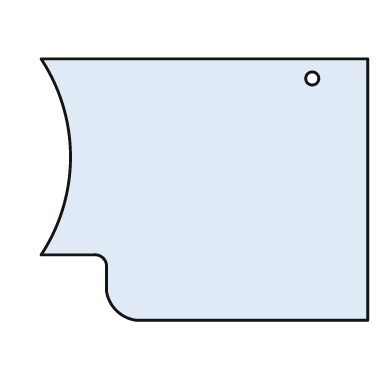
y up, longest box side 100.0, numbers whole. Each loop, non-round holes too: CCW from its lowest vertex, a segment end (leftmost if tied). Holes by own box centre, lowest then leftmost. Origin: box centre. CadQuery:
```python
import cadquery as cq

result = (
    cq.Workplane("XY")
    .moveTo(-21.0, -40.0)
    .lineTo(50.0, -40.0)
    .lineTo(50.0, 40.0)
    .lineTo(-50.0, 40.0)
    .threePointArc((-41.0, 10.0), (-50.0, -20.0))
    .lineTo(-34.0, -20.0)
    .threePointArc((-31.0, -21.0), (-30.0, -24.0))
    .lineTo(-30.0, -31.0)
    .threePointArc((-27.0, -37.0), (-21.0, -40.0))
    .close()
    .moveTo(33.0, 34.0)
    .circle(2.0)
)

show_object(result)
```